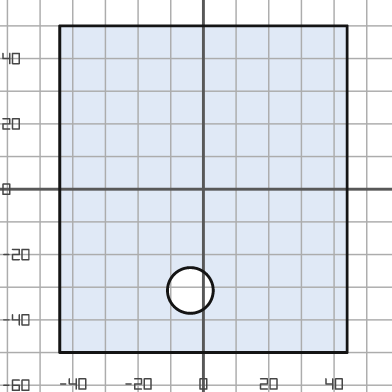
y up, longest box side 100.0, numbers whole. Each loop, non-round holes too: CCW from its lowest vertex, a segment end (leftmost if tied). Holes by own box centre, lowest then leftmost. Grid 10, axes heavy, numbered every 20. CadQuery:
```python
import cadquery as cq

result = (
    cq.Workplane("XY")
    .moveTo(-44.0, -50.0)
    .lineTo(44.0, -50.0)
    .lineTo(44.0, 50.0)
    .lineTo(-44.0, 50.0)
    .close()
    .moveTo(-4.0, -31.0)
    .circle(7.0)
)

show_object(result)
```